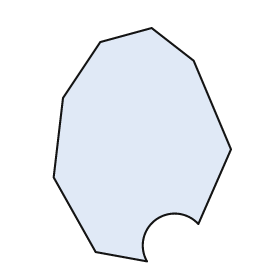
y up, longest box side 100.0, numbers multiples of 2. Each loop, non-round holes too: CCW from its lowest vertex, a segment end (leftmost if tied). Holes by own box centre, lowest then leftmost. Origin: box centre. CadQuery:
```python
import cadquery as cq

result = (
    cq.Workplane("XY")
    .moveTo(2.0, -50.0)
    .threePointArc((6.0, -32.0), (24.0, -34.0))
    .lineTo(38.0, -2.0)
    .lineTo(22.0, 36.0)
    .lineTo(4.0, 50.0)
    .lineTo(-18.0, 44.0)
    .lineTo(-34.0, 20.0)
    .lineTo(-38.0, -14.0)
    .lineTo(-20.0, -46.0)
    .close()
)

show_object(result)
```